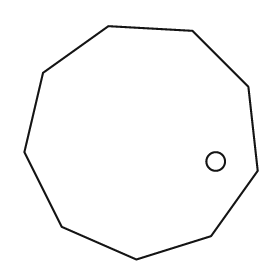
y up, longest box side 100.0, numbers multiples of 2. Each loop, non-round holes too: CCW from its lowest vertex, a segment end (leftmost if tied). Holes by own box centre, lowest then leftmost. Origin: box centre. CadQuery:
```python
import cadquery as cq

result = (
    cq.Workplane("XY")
    .moveTo(-2.0, -50.0)
    .lineTo(30.0, -40.0)
    .lineTo(50.0, -12.0)
    .lineTo(46.0, 24.0)
    .lineTo(22.0, 48.0)
    .lineTo(-14.0, 50.0)
    .lineTo(-42.0, 30.0)
    .lineTo(-50.0, -4.0)
    .lineTo(-34.0, -36.0)
    .close()
    .moveTo(32.0, -8.0)
    .circle(4.0)
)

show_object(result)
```